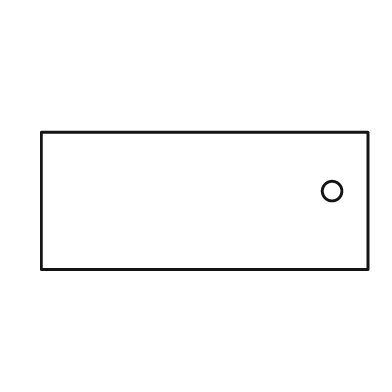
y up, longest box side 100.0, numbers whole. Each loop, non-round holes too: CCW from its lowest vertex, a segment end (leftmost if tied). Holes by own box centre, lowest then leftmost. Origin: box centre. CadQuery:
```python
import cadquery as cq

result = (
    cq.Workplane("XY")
    .moveTo(-50.0, -21.0)
    .lineTo(50.0, -21.0)
    .lineTo(50.0, 21.0)
    .lineTo(-50.0, 21.0)
    .close()
    .moveTo(39.0, 3.0)
    .circle(3.0)
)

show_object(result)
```